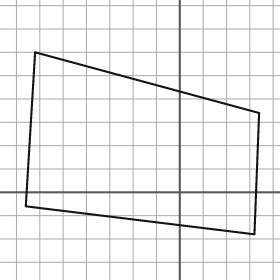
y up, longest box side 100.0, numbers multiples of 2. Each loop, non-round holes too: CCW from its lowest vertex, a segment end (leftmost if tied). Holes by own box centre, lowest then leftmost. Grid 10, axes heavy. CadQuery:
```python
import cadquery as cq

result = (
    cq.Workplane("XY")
    .moveTo(32.0, -18.0)
    .lineTo(34.0, 34.0)
    .lineTo(-62.0, 60.0)
    .lineTo(-66.0, -6.0)
    .close()
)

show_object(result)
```